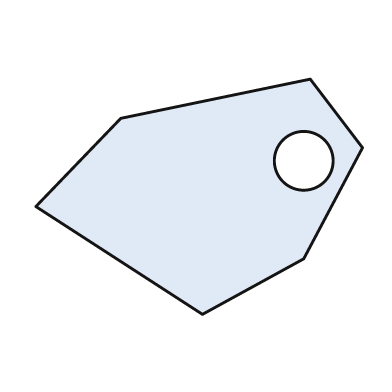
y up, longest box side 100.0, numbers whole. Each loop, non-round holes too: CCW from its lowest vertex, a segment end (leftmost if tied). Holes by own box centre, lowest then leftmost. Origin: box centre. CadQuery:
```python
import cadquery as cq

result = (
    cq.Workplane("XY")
    .moveTo(1.0, -36.0)
    .lineTo(32.0, -19.0)
    .lineTo(50.0, 15.0)
    .lineTo(34.0, 36.0)
    .lineTo(-24.0, 24.0)
    .lineTo(-50.0, -3.0)
    .close()
    .moveTo(32.0, 11.0)
    .circle(9.0)
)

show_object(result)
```